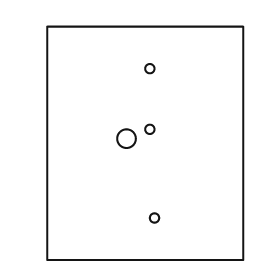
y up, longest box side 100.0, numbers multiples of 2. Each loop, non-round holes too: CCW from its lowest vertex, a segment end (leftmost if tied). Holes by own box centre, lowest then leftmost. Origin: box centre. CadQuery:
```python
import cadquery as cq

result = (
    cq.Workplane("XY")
    .moveTo(-42.0, -50.0)
    .lineTo(42.0, -50.0)
    .lineTo(42.0, 50.0)
    .lineTo(-42.0, 50.0)
    .close()
    .moveTo(4.0, -32.0)
    .circle(2.0)
    .moveTo(-8.0, 2.0)
    .circle(4.0)
    .moveTo(2.0, 6.0)
    .circle(2.0)
    .moveTo(2.0, 32.0)
    .circle(2.0)
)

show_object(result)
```